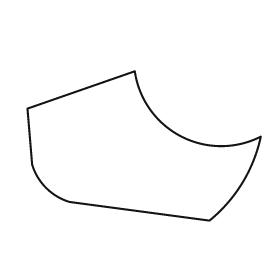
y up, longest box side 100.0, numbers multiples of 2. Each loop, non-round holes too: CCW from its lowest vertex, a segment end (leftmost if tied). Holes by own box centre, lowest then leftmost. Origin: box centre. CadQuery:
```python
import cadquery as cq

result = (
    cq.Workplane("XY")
    .moveTo(28.0, -32.0)
    .threePointArc((42.0, -16.0), (50.0, 4.0))
    .threePointArc((16.0, 4.0), (-4.0, 32.0))
    .lineTo(-50.0, 16.0)
    .lineTo(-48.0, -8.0)
    .threePointArc((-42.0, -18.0), (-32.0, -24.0))
    .close()
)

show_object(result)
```